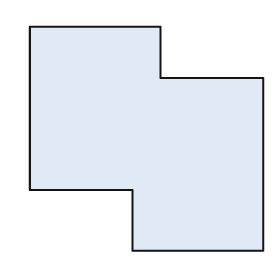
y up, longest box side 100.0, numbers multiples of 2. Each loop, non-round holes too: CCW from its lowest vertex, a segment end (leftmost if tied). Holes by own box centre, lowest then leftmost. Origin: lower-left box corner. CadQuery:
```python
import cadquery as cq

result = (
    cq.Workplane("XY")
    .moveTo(44.0, 0.0)
    .lineTo(100.0, 0.0)
    .lineTo(100.0, 74.0)
    .lineTo(56.0, 74.0)
    .lineTo(56.0, 96.0)
    .lineTo(0.0, 96.0)
    .lineTo(0.0, 26.0)
    .lineTo(44.0, 26.0)
    .close()
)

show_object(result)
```